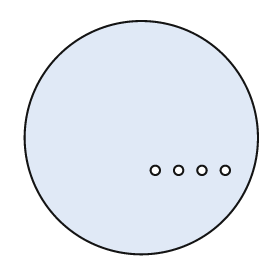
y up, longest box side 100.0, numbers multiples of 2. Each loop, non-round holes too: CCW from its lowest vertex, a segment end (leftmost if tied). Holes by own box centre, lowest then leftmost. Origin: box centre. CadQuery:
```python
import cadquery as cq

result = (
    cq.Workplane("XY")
    .moveTo(0.0, 0.0)
    .circle(50.0)
    .moveTo(6.0, -14.0)
    .circle(2.0)
    .moveTo(16.0, -14.0)
    .circle(2.0)
    .moveTo(26.0, -14.0)
    .circle(2.0)
    .moveTo(36.0, -14.0)
    .circle(2.0)
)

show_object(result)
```